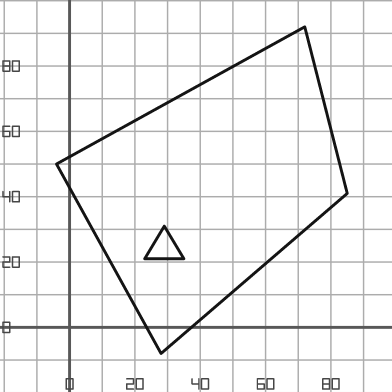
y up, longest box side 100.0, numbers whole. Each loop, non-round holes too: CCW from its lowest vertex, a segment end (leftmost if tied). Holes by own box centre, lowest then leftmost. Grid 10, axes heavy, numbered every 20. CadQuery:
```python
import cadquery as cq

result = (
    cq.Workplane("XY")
    .moveTo(28.0, -8.0)
    .lineTo(85.0, 41.0)
    .lineTo(72.0, 92.0)
    .lineTo(-4.0, 50.0)
    .close()
    .moveTo(23.0, 21.0)
    .lineTo(35.0, 21.0)
    .lineTo(29.0, 31.0)
    .close()
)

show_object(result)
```